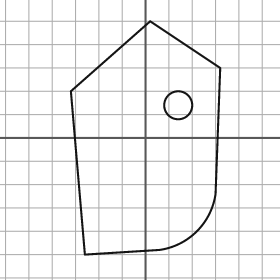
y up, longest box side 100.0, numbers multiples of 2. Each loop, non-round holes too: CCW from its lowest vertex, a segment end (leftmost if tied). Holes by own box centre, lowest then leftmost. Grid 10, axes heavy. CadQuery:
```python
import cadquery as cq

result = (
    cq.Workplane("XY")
    .moveTo(-26.0, -50.0)
    .lineTo(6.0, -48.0)
    .threePointArc((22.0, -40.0), (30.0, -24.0))
    .lineTo(32.0, 30.0)
    .lineTo(2.0, 50.0)
    .lineTo(-32.0, 20.0)
    .close()
    .moveTo(14.0, 14.0)
    .circle(6.0)
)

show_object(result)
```